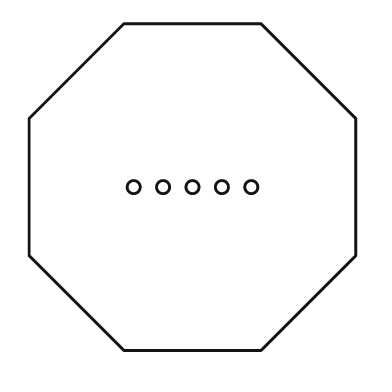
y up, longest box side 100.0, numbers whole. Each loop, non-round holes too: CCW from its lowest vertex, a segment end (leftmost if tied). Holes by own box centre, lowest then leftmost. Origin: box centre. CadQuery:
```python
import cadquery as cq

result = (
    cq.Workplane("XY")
    .moveTo(-21.0, -50.0)
    .lineTo(21.0, -50.0)
    .lineTo(50.0, -21.0)
    .lineTo(50.0, 21.0)
    .lineTo(21.0, 50.0)
    .lineTo(-21.0, 50.0)
    .lineTo(-50.0, 21.0)
    .lineTo(-50.0, -21.0)
    .close()
    .moveTo(-18.0, 0.0)
    .circle(2.0)
    .moveTo(-9.0, 0.0)
    .circle(2.0)
    .moveTo(0.0, 0.0)
    .circle(2.0)
    .moveTo(9.0, 0.0)
    .circle(2.0)
    .moveTo(18.0, 0.0)
    .circle(2.0)
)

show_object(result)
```